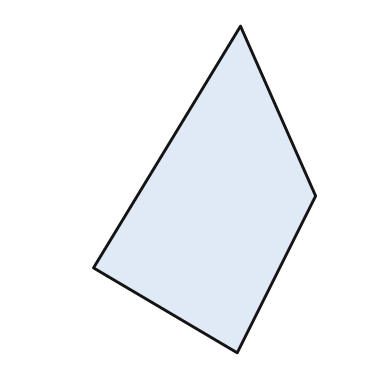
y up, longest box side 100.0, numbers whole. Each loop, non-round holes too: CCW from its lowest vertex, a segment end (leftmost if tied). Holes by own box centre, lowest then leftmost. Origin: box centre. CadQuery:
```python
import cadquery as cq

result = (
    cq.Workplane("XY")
    .moveTo(10.0, -50.0)
    .lineTo(34.0, -2.0)
    .lineTo(11.0, 50.0)
    .lineTo(-34.0, -24.0)
    .close()
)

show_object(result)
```